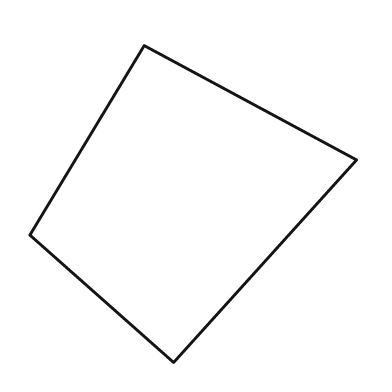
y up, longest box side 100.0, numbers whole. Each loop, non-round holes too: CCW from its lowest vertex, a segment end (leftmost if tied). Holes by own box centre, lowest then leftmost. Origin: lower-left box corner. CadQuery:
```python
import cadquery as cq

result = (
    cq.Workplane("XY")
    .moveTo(44.0, 0.0)
    .lineTo(100.0, 62.0)
    .lineTo(35.0, 97.0)
    .lineTo(0.0, 39.0)
    .close()
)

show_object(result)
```